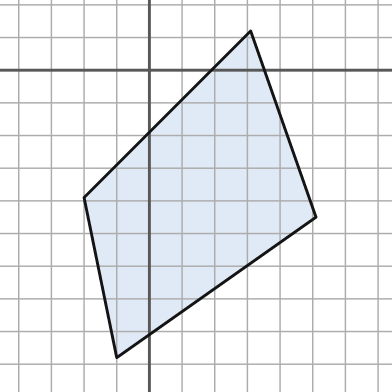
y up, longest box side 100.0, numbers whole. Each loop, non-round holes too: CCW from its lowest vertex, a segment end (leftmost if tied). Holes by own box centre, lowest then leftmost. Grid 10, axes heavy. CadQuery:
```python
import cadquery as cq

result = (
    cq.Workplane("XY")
    .moveTo(-10.0, -88.0)
    .lineTo(51.0, -45.0)
    .lineTo(31.0, 12.0)
    .lineTo(-20.0, -39.0)
    .close()
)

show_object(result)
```